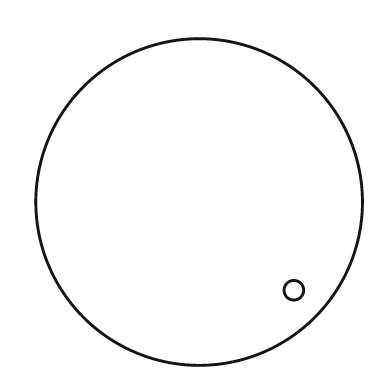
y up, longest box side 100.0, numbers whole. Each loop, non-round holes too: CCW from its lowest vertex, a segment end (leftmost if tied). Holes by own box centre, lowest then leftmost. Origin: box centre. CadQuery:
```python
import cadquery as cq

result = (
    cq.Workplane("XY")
    .moveTo(0.0, 0.0)
    .circle(50.0)
    .moveTo(29.0, -27.0)
    .circle(3.0)
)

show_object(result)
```